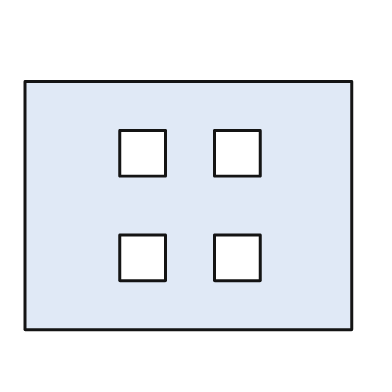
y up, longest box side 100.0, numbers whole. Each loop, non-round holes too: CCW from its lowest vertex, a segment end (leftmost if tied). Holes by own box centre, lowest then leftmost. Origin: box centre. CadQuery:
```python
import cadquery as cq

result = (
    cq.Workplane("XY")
    .moveTo(-50.0, -38.0)
    .lineTo(50.0, -38.0)
    .lineTo(50.0, 38.0)
    .lineTo(-50.0, 38.0)
    .close()
    .moveTo(-21.0, -23.0)
    .lineTo(-7.0, -23.0)
    .lineTo(-7.0, -9.0)
    .lineTo(-21.0, -9.0)
    .close()
    .moveTo(8.0, -23.0)
    .lineTo(22.0, -23.0)
    .lineTo(22.0, -9.0)
    .lineTo(8.0, -9.0)
    .close()
    .moveTo(-21.0, 9.0)
    .lineTo(-7.0, 9.0)
    .lineTo(-7.0, 23.0)
    .lineTo(-21.0, 23.0)
    .close()
    .moveTo(8.0, 9.0)
    .lineTo(22.0, 9.0)
    .lineTo(22.0, 23.0)
    .lineTo(8.0, 23.0)
    .close()
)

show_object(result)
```